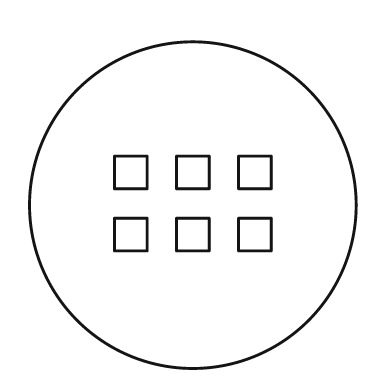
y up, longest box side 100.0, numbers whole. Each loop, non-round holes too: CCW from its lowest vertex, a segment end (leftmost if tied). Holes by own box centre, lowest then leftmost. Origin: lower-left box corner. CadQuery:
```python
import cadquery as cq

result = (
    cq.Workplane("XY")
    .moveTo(50.0, 50.0)
    .circle(50.0)
    .moveTo(26.0, 36.0)
    .lineTo(36.0, 36.0)
    .lineTo(36.0, 46.0)
    .lineTo(26.0, 46.0)
    .close()
    .moveTo(45.0, 36.0)
    .lineTo(55.0, 36.0)
    .lineTo(55.0, 46.0)
    .lineTo(45.0, 46.0)
    .close()
    .moveTo(64.0, 36.0)
    .lineTo(74.0, 36.0)
    .lineTo(74.0, 46.0)
    .lineTo(64.0, 46.0)
    .close()
    .moveTo(26.0, 55.0)
    .lineTo(36.0, 55.0)
    .lineTo(36.0, 65.0)
    .lineTo(26.0, 65.0)
    .close()
    .moveTo(45.0, 55.0)
    .lineTo(55.0, 55.0)
    .lineTo(55.0, 65.0)
    .lineTo(45.0, 65.0)
    .close()
    .moveTo(64.0, 55.0)
    .lineTo(74.0, 55.0)
    .lineTo(74.0, 65.0)
    .lineTo(64.0, 65.0)
    .close()
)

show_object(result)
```